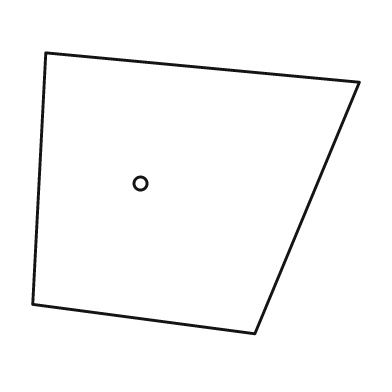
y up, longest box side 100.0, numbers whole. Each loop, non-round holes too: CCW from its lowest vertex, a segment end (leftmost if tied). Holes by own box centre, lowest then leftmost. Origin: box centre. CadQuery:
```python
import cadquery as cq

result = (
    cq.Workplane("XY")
    .moveTo(18.0, -43.0)
    .lineTo(50.0, 34.0)
    .lineTo(-46.0, 43.0)
    .lineTo(-50.0, -34.0)
    .close()
    .moveTo(-17.0, 3.0)
    .circle(2.0)
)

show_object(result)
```